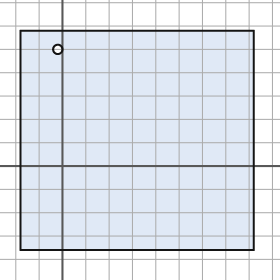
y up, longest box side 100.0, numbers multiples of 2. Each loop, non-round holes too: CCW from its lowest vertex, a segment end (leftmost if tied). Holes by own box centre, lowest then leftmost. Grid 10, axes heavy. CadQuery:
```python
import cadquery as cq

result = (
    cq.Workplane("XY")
    .moveTo(-18.0, -36.0)
    .lineTo(82.0, -36.0)
    .lineTo(82.0, 58.0)
    .lineTo(-18.0, 58.0)
    .close()
    .moveTo(-2.0, 50.0)
    .circle(2.0)
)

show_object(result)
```